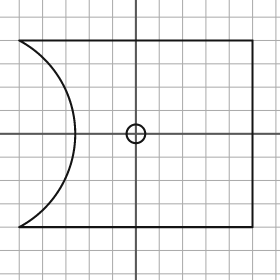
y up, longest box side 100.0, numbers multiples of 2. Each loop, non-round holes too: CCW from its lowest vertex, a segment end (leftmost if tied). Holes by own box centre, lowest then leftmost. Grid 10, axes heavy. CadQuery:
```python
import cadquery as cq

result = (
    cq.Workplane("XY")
    .moveTo(-50.0, -40.0)
    .lineTo(50.0, -40.0)
    .lineTo(50.0, 40.0)
    .lineTo(-50.0, 40.0)
    .threePointArc((-26.0, 0.0), (-50.0, -40.0))
    .close()
    .moveTo(0.0, 0.0)
    .circle(4.0)
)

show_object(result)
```